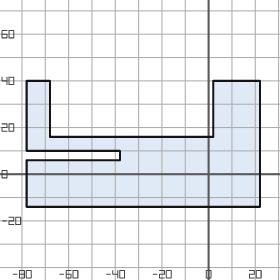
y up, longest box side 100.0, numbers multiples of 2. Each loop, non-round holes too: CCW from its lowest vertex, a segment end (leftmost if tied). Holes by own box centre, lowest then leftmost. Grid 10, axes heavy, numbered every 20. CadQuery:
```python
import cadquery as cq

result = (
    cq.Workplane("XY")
    .moveTo(-78.0, -14.0)
    .lineTo(22.0, -14.0)
    .lineTo(22.0, 40.0)
    .lineTo(2.0, 40.0)
    .lineTo(2.0, 16.0)
    .lineTo(-68.0, 16.0)
    .lineTo(-68.0, 40.0)
    .lineTo(-78.0, 40.0)
    .lineTo(-78.0, 10.0)
    .lineTo(-38.0, 10.0)
    .lineTo(-38.0, 6.0)
    .lineTo(-78.0, 6.0)
    .close()
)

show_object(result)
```